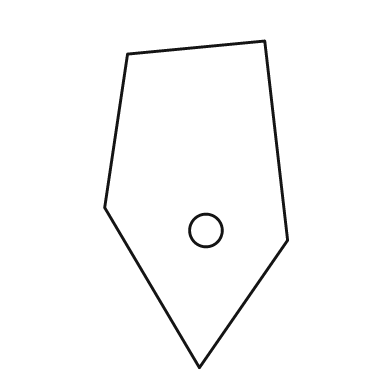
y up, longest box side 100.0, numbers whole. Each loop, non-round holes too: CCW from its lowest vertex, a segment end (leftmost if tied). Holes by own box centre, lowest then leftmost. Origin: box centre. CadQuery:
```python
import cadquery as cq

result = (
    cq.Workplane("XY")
    .moveTo(1.0, -50.0)
    .lineTo(28.0, -11.0)
    .lineTo(21.0, 50.0)
    .lineTo(-21.0, 46.0)
    .lineTo(-28.0, -1.0)
    .close()
    .moveTo(3.0, -8.0)
    .circle(5.0)
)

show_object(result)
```